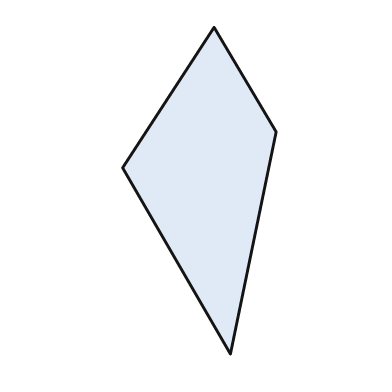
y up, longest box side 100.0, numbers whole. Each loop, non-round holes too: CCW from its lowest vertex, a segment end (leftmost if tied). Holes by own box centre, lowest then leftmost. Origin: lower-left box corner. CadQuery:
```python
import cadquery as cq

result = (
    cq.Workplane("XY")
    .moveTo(33.0, 0.0)
    .lineTo(47.0, 68.0)
    .lineTo(28.0, 100.0)
    .lineTo(0.0, 57.0)
    .close()
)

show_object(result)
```